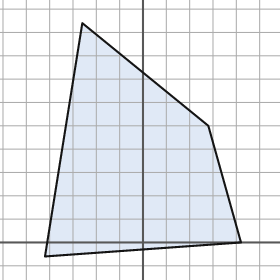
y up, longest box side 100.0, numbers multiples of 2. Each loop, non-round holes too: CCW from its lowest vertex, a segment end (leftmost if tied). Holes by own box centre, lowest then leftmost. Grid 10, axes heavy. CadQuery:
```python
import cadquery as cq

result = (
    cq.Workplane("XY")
    .moveTo(-42.0, -6.0)
    .lineTo(42.0, 0.0)
    .lineTo(28.0, 50.0)
    .lineTo(-26.0, 94.0)
    .close()
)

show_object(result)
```